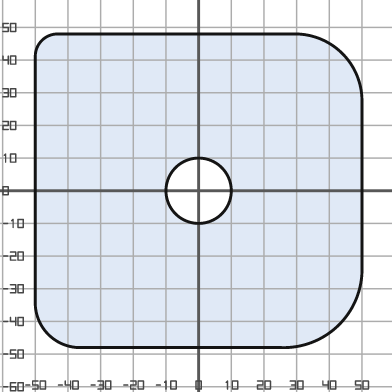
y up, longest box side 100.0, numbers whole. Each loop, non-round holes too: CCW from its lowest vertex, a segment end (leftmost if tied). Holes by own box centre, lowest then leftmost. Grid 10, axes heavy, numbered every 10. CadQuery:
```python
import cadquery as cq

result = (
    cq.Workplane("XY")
    .moveTo(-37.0, -48.0)
    .lineTo(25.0, -48.0)
    .threePointArc((43.0, -41.0), (50.0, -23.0))
    .lineTo(50.0, 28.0)
    .threePointArc((44.0, 42.0), (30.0, 48.0))
    .lineTo(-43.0, 48.0)
    .threePointArc((-48.0, 46.0), (-50.0, 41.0))
    .lineTo(-50.0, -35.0)
    .threePointArc((-46.0, -44.0), (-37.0, -48.0))
    .close()
    .moveTo(0.0, 0.0)
    .circle(10.0)
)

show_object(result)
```